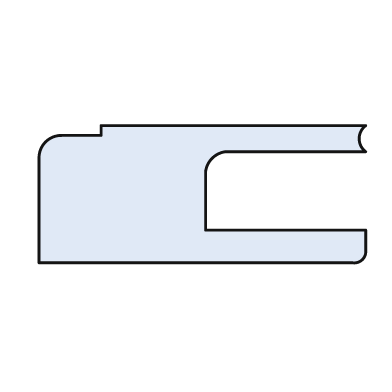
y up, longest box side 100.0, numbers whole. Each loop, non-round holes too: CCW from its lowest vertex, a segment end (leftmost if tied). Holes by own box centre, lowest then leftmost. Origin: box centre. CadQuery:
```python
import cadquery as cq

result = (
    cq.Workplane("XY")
    .moveTo(-50.0, -21.0)
    .lineTo(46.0, -21.0)
    .threePointArc((49.0, -20.0), (50.0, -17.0))
    .lineTo(50.0, -11.0)
    .lineTo(1.0, -11.0)
    .lineTo(1.0, 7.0)
    .threePointArc((3.0, 11.0), (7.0, 13.0))
    .lineTo(50.0, 13.0)
    .threePointArc((48.0, 17.0), (50.0, 21.0))
    .lineTo(-31.0, 21.0)
    .lineTo(-31.0, 18.0)
    .lineTo(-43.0, 18.0)
    .threePointArc((-48.0, 16.0), (-50.0, 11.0))
    .close()
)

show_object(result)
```